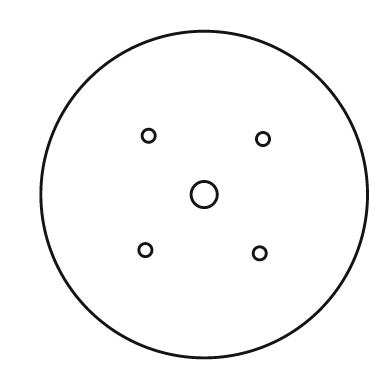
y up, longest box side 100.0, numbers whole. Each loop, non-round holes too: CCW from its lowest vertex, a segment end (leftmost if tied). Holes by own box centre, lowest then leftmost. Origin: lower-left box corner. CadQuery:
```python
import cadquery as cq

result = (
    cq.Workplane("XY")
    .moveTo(50.0, 50.0)
    .circle(50.0)
    .moveTo(67.0, 32.0)
    .circle(2.0)
    .moveTo(32.0, 33.0)
    .circle(2.0)
    .moveTo(50.0, 50.0)
    .circle(4.0)
    .moveTo(68.0, 67.0)
    .circle(2.0)
    .moveTo(33.0, 68.0)
    .circle(2.0)
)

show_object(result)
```